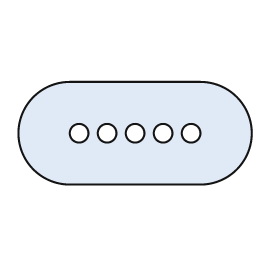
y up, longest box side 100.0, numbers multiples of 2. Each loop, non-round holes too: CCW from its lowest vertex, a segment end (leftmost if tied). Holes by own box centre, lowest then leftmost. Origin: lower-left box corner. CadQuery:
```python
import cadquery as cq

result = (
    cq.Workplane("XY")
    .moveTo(22.0, 0.0)
    .lineTo(78.0, 0.0)
    .threePointArc((100.0, 22.0), (78.0, 44.0))
    .lineTo(22.0, 44.0)
    .threePointArc((0.0, 22.0), (22.0, 0.0))
    .close()
    .moveTo(26.0, 22.0)
    .circle(4.0)
    .moveTo(38.0, 22.0)
    .circle(4.0)
    .moveTo(50.0, 22.0)
    .circle(4.0)
    .moveTo(62.0, 22.0)
    .circle(4.0)
    .moveTo(74.0, 22.0)
    .circle(4.0)
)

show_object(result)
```